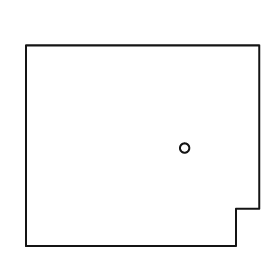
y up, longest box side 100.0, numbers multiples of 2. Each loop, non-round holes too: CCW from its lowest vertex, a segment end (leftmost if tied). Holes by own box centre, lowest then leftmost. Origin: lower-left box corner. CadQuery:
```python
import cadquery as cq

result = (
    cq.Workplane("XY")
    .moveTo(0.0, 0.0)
    .lineTo(90.0, 0.0)
    .lineTo(90.0, 16.0)
    .lineTo(100.0, 16.0)
    .lineTo(100.0, 86.0)
    .lineTo(0.0, 86.0)
    .close()
    .moveTo(68.0, 42.0)
    .circle(2.0)
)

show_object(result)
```